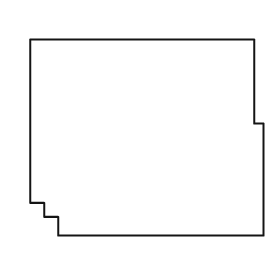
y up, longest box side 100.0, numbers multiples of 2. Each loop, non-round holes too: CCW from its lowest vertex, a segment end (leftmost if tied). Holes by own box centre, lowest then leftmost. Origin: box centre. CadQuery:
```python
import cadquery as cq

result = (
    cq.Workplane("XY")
    .moveTo(-38.0, -42.0)
    .lineTo(50.0, -42.0)
    .lineTo(50.0, 6.0)
    .lineTo(46.0, 6.0)
    .lineTo(46.0, 42.0)
    .lineTo(-50.0, 42.0)
    .lineTo(-50.0, -28.0)
    .lineTo(-44.0, -28.0)
    .lineTo(-44.0, -34.0)
    .lineTo(-38.0, -34.0)
    .close()
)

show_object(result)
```